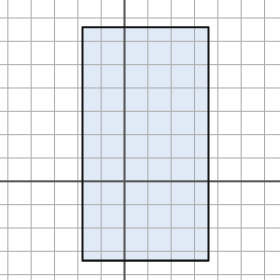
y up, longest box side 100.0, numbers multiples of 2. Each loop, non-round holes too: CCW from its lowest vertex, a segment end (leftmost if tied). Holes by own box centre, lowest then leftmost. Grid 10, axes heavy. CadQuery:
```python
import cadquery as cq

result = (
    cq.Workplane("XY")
    .moveTo(-18.0, -34.0)
    .lineTo(36.0, -34.0)
    .lineTo(36.0, 66.0)
    .lineTo(-18.0, 66.0)
    .close()
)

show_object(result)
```